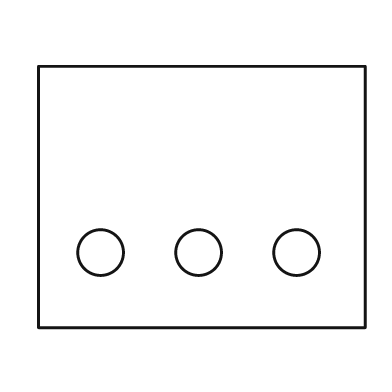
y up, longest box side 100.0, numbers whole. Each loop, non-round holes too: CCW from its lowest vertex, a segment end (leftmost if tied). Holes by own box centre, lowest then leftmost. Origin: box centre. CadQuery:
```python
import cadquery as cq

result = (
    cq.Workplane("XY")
    .moveTo(-50.0, -40.0)
    .lineTo(50.0, -40.0)
    .lineTo(50.0, 40.0)
    .lineTo(-50.0, 40.0)
    .close()
    .moveTo(-31.0, -17.0)
    .circle(7.0)
    .moveTo(-1.0, -17.0)
    .circle(7.0)
    .moveTo(29.0, -17.0)
    .circle(7.0)
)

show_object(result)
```